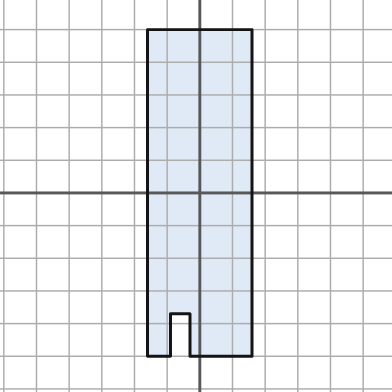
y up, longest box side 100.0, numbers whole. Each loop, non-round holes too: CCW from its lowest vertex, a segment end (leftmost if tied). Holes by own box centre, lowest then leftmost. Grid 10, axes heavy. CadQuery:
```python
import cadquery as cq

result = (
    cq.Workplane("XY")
    .moveTo(-16.0, -50.0)
    .lineTo(-9.0, -50.0)
    .lineTo(-9.0, -37.0)
    .lineTo(-3.0, -37.0)
    .lineTo(-3.0, -50.0)
    .lineTo(16.0, -50.0)
    .lineTo(16.0, 50.0)
    .lineTo(-16.0, 50.0)
    .close()
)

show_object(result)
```